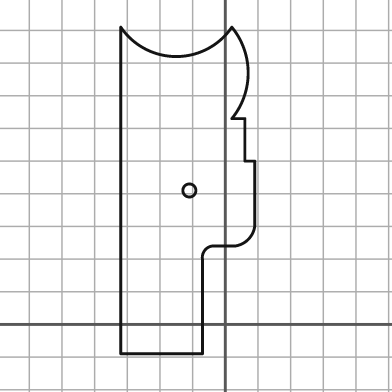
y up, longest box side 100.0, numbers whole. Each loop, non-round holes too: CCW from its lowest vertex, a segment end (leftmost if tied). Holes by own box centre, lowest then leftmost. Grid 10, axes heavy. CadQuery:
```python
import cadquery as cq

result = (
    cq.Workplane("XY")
    .moveTo(-32.0, -9.0)
    .lineTo(-7.0, -9.0)
    .lineTo(-7.0, 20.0)
    .threePointArc((-6.0, 23.0), (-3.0, 24.0))
    .lineTo(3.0, 24.0)
    .threePointArc((7.0, 26.0), (9.0, 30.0))
    .lineTo(9.0, 50.0)
    .lineTo(6.0, 50.0)
    .lineTo(6.0, 63.0)
    .lineTo(2.0, 63.0)
    .threePointArc((7.0, 77.0), (2.0, 91.0))
    .threePointArc((-15.0, 82.0), (-32.0, 91.0))
    .close()
    .moveTo(-11.0, 41.0)
    .circle(2.0)
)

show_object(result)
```